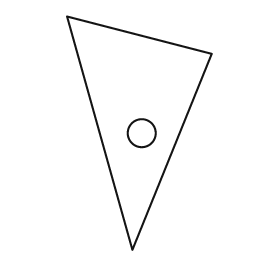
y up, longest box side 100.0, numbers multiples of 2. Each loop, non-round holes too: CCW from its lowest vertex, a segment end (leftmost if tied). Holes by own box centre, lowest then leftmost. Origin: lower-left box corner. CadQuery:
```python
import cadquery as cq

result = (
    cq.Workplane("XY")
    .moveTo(28.0, 0.0)
    .lineTo(62.0, 84.0)
    .lineTo(0.0, 100.0)
    .close()
    .moveTo(32.0, 50.0)
    .circle(6.0)
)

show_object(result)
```